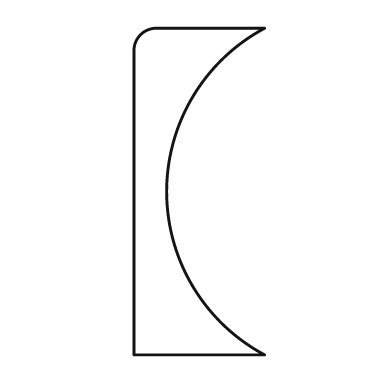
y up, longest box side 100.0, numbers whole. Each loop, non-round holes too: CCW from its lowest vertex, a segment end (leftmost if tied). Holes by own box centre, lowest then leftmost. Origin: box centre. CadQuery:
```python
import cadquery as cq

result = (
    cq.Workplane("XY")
    .moveTo(-20.0, -50.0)
    .lineTo(20.0, -50.0)
    .threePointArc((-10.0, 0.0), (20.0, 50.0))
    .lineTo(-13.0, 50.0)
    .threePointArc((-18.0, 48.0), (-20.0, 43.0))
    .close()
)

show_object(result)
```